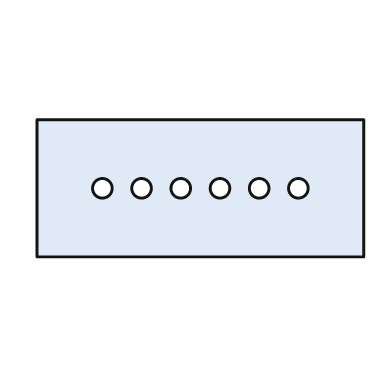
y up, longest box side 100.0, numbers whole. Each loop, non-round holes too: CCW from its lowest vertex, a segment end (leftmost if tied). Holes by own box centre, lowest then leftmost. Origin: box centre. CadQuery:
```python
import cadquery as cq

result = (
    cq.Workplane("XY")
    .moveTo(-50.0, -21.0)
    .lineTo(50.0, -21.0)
    .lineTo(50.0, 21.0)
    .lineTo(-50.0, 21.0)
    .close()
    .moveTo(-30.0, 0.0)
    .circle(3.0)
    .moveTo(-18.0, 0.0)
    .circle(3.0)
    .moveTo(-6.0, 0.0)
    .circle(3.0)
    .moveTo(6.0, 0.0)
    .circle(3.0)
    .moveTo(18.0, 0.0)
    .circle(3.0)
    .moveTo(30.0, 0.0)
    .circle(3.0)
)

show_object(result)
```